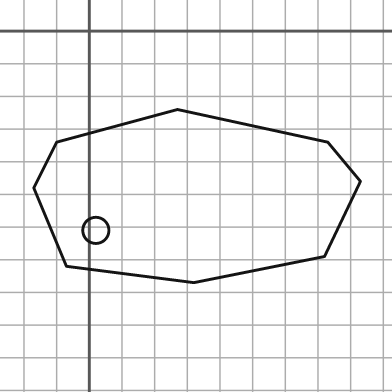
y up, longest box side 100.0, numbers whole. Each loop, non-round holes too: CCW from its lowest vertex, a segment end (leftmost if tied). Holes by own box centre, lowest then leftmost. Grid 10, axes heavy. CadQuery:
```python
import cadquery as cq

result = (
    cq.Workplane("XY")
    .moveTo(32.0, -77.0)
    .lineTo(72.0, -69.0)
    .lineTo(83.0, -46.0)
    .lineTo(73.0, -34.0)
    .lineTo(27.0, -24.0)
    .lineTo(-10.0, -34.0)
    .lineTo(-17.0, -48.0)
    .lineTo(-7.0, -72.0)
    .close()
    .moveTo(2.0, -61.0)
    .circle(4.0)
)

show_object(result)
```